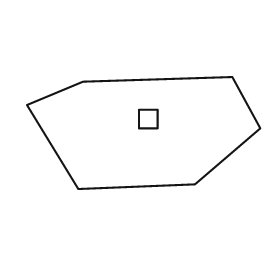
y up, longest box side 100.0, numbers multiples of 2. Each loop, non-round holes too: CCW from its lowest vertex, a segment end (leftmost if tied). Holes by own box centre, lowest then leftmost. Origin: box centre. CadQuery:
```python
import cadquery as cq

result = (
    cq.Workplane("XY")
    .moveTo(-28.0, -24.0)
    .lineTo(22.0, -22.0)
    .lineTo(50.0, 2.0)
    .lineTo(38.0, 24.0)
    .lineTo(-26.0, 22.0)
    .lineTo(-50.0, 12.0)
    .close()
    .moveTo(-2.0, 2.0)
    .lineTo(6.0, 2.0)
    .lineTo(6.0, 10.0)
    .lineTo(-2.0, 10.0)
    .close()
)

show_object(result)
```